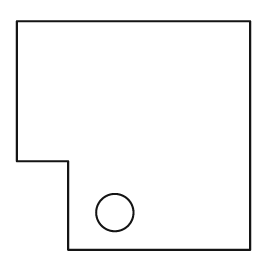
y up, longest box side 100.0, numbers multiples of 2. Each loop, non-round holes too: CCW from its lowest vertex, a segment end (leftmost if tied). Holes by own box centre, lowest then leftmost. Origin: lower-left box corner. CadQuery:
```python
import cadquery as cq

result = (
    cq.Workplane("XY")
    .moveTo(22.0, 0.0)
    .lineTo(100.0, 0.0)
    .lineTo(100.0, 98.0)
    .lineTo(0.0, 98.0)
    .lineTo(0.0, 38.0)
    .lineTo(22.0, 38.0)
    .close()
    .moveTo(42.0, 16.0)
    .circle(8.0)
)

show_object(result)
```